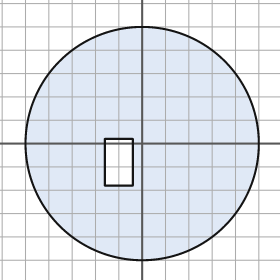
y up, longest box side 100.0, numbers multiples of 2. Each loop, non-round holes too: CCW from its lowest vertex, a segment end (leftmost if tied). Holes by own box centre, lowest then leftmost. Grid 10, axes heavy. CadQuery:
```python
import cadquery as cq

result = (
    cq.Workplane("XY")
    .moveTo(0.0, 0.0)
    .circle(50.0)
    .moveTo(-16.0, -18.0)
    .lineTo(-4.0, -18.0)
    .lineTo(-4.0, 2.0)
    .lineTo(-16.0, 2.0)
    .close()
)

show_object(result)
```